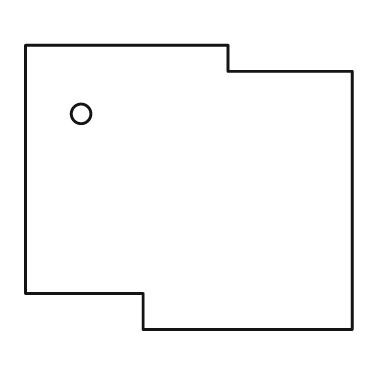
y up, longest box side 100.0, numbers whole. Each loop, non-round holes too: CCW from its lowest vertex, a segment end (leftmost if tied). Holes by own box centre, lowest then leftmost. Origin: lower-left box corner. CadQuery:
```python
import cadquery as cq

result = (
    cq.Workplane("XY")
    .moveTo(36.0, 0.0)
    .lineTo(100.0, 0.0)
    .lineTo(100.0, 79.0)
    .lineTo(62.0, 79.0)
    .lineTo(62.0, 87.0)
    .lineTo(0.0, 87.0)
    .lineTo(0.0, 11.0)
    .lineTo(36.0, 11.0)
    .close()
    .moveTo(17.0, 66.0)
    .circle(3.0)
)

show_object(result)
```